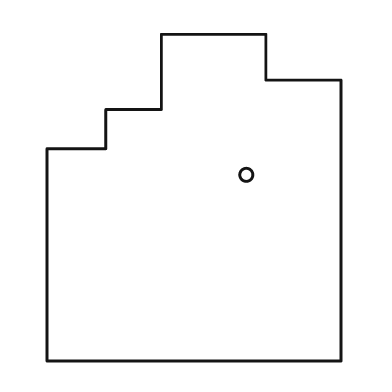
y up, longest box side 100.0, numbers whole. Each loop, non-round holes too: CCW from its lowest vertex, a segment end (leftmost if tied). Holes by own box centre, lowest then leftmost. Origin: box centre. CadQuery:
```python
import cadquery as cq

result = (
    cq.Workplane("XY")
    .moveTo(-45.0, -50.0)
    .lineTo(45.0, -50.0)
    .lineTo(45.0, 36.0)
    .lineTo(22.0, 36.0)
    .lineTo(22.0, 50.0)
    .lineTo(-10.0, 50.0)
    .lineTo(-10.0, 27.0)
    .lineTo(-27.0, 27.0)
    .lineTo(-27.0, 15.0)
    .lineTo(-45.0, 15.0)
    .close()
    .moveTo(16.0, 7.0)
    .circle(2.0)
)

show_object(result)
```